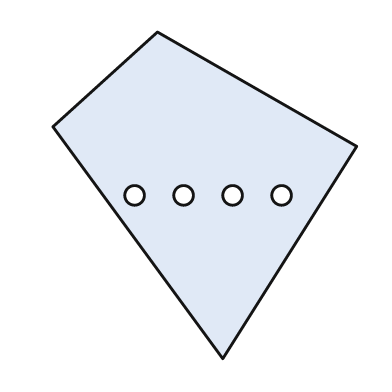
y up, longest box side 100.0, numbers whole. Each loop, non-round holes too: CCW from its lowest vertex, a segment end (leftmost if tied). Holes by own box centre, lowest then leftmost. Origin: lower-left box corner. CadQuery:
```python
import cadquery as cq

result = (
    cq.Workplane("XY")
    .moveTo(52.0, 0.0)
    .lineTo(93.0, 65.0)
    .lineTo(32.0, 100.0)
    .lineTo(0.0, 71.0)
    .close()
    .moveTo(25.0, 50.0)
    .circle(3.0)
    .moveTo(40.0, 50.0)
    .circle(3.0)
    .moveTo(55.0, 50.0)
    .circle(3.0)
    .moveTo(70.0, 50.0)
    .circle(3.0)
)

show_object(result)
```